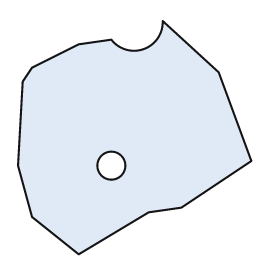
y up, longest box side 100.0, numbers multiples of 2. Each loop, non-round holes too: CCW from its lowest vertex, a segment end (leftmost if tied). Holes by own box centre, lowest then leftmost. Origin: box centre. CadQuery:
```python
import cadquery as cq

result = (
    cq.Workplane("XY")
    .moveTo(-24.0, -50.0)
    .lineTo(6.0, -32.0)
    .lineTo(20.0, -30.0)
    .lineTo(50.0, -10.0)
    .lineTo(36.0, 28.0)
    .lineTo(12.0, 50.0)
    .threePointArc((4.0, 38.0), (-10.0, 42.0))
    .lineTo(-24.0, 40.0)
    .lineTo(-44.0, 30.0)
    .lineTo(-48.0, 24.0)
    .lineTo(-50.0, -12.0)
    .lineTo(-44.0, -34.0)
    .close()
    .moveTo(-10.0, -12.0)
    .circle(6.0)
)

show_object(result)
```